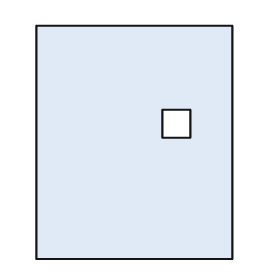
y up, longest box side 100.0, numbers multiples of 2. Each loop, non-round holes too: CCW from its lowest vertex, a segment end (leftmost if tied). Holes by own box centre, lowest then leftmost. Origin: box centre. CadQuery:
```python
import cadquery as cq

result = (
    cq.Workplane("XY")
    .moveTo(-42.0, -50.0)
    .lineTo(42.0, -50.0)
    .lineTo(42.0, 50.0)
    .lineTo(-42.0, 50.0)
    .close()
    .moveTo(12.0, 2.0)
    .lineTo(24.0, 2.0)
    .lineTo(24.0, 14.0)
    .lineTo(12.0, 14.0)
    .close()
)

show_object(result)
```